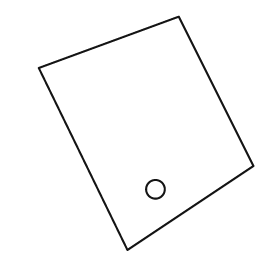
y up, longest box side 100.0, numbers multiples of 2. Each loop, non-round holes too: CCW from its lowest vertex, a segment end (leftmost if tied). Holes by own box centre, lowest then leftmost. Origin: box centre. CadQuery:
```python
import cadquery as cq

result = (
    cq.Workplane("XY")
    .moveTo(-8.0, -50.0)
    .lineTo(46.0, -14.0)
    .lineTo(14.0, 50.0)
    .lineTo(-46.0, 28.0)
    .close()
    .moveTo(4.0, -24.0)
    .circle(4.0)
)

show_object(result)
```